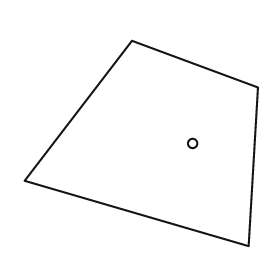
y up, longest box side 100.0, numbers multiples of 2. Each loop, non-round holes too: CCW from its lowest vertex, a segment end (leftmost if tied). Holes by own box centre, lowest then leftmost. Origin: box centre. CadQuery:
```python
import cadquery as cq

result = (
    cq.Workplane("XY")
    .moveTo(46.0, -44.0)
    .lineTo(50.0, 24.0)
    .lineTo(-4.0, 44.0)
    .lineTo(-50.0, -16.0)
    .close()
    .moveTo(22.0, 0.0)
    .circle(2.0)
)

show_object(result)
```